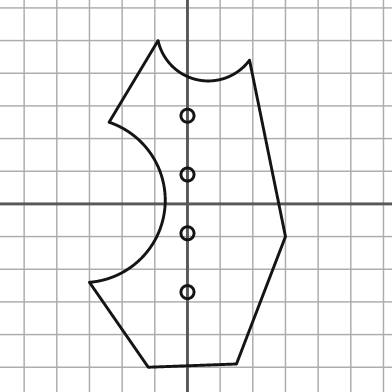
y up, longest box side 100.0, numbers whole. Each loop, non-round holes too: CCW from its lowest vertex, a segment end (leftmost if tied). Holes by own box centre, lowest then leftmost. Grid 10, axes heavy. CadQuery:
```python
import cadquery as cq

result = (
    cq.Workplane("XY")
    .moveTo(-12.0, -50.0)
    .lineTo(15.0, -49.0)
    .lineTo(30.0, -10.0)
    .lineTo(19.0, 44.0)
    .threePointArc((3.0, 38.0), (-9.0, 50.0))
    .lineTo(-24.0, 25.0)
    .threePointArc((-7.0, -2.0), (-30.0, -24.0))
    .close()
    .moveTo(0.0, -27.0)
    .circle(2.0)
    .moveTo(0.0, -9.0)
    .circle(2.0)
    .moveTo(0.0, 9.0)
    .circle(2.0)
    .moveTo(0.0, 27.0)
    .circle(2.0)
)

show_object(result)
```